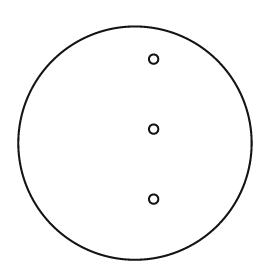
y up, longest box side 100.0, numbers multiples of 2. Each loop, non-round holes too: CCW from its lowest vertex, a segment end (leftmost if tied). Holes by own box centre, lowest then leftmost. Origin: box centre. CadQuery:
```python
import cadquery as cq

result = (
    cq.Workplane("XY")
    .moveTo(0.0, 0.0)
    .circle(50.0)
    .moveTo(8.0, -24.0)
    .circle(2.0)
    .moveTo(8.0, 6.0)
    .circle(2.0)
    .moveTo(8.0, 36.0)
    .circle(2.0)
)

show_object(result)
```